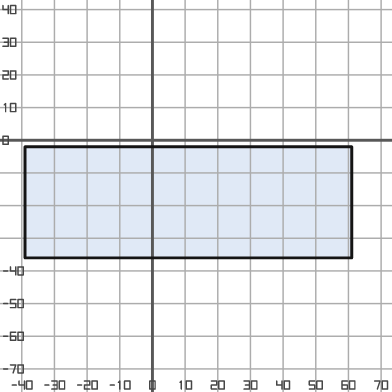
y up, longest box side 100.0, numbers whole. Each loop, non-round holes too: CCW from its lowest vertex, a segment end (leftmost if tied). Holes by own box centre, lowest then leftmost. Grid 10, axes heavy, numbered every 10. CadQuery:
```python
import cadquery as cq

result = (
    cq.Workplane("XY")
    .moveTo(-39.0, -36.0)
    .lineTo(61.0, -36.0)
    .lineTo(61.0, -2.0)
    .lineTo(-39.0, -2.0)
    .close()
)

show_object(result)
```